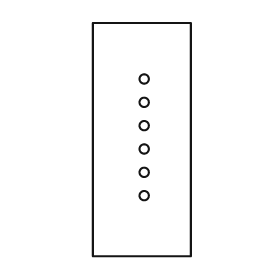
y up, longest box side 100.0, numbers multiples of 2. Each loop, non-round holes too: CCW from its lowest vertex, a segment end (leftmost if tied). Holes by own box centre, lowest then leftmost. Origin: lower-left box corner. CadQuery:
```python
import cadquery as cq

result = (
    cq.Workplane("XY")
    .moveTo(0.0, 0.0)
    .lineTo(42.0, 0.0)
    .lineTo(42.0, 100.0)
    .lineTo(0.0, 100.0)
    .close()
    .moveTo(22.0, 26.0)
    .circle(2.0)
    .moveTo(22.0, 36.0)
    .circle(2.0)
    .moveTo(22.0, 46.0)
    .circle(2.0)
    .moveTo(22.0, 56.0)
    .circle(2.0)
    .moveTo(22.0, 66.0)
    .circle(2.0)
    .moveTo(22.0, 76.0)
    .circle(2.0)
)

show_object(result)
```